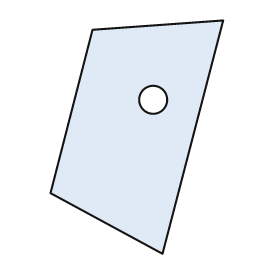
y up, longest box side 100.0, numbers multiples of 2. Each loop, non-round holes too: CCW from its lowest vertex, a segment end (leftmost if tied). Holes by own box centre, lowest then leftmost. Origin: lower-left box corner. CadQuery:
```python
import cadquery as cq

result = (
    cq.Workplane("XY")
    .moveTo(48.0, 0.0)
    .lineTo(74.0, 100.0)
    .lineTo(18.0, 96.0)
    .lineTo(0.0, 26.0)
    .close()
    .moveTo(44.0, 66.0)
    .circle(6.0)
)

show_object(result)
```